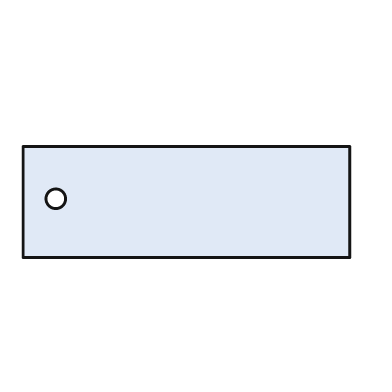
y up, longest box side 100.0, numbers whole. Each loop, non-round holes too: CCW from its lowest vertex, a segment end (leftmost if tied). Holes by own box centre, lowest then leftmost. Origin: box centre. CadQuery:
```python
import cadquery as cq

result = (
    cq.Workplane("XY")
    .moveTo(-50.0, -17.0)
    .lineTo(50.0, -17.0)
    .lineTo(50.0, 17.0)
    .lineTo(-50.0, 17.0)
    .close()
    .moveTo(-40.0, 1.0)
    .circle(3.0)
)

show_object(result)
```